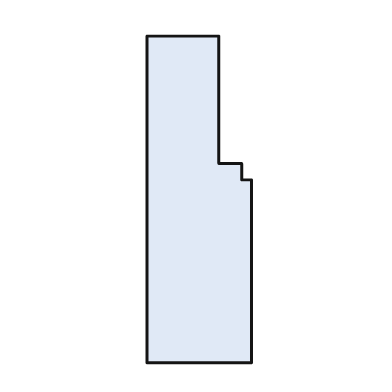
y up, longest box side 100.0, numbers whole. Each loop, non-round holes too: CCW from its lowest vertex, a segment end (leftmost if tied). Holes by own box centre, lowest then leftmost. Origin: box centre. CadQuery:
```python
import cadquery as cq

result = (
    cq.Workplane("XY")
    .moveTo(-16.0, -50.0)
    .lineTo(16.0, -50.0)
    .lineTo(16.0, 6.0)
    .lineTo(13.0, 6.0)
    .lineTo(13.0, 11.0)
    .lineTo(6.0, 11.0)
    .lineTo(6.0, 50.0)
    .lineTo(-16.0, 50.0)
    .close()
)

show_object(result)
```